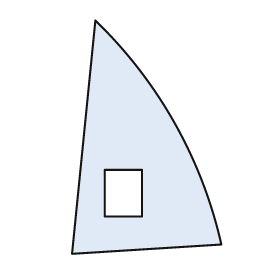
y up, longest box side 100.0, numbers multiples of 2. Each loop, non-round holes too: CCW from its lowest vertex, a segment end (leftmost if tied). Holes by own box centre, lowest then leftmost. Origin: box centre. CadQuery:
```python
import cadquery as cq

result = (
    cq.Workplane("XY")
    .moveTo(-32.0, -50.0)
    .lineTo(32.0, -46.0)
    .threePointArc((12.0, 6.0), (-22.0, 50.0))
    .close()
    .moveTo(-18.0, -34.0)
    .lineTo(-2.0, -34.0)
    .lineTo(-2.0, -14.0)
    .lineTo(-18.0, -14.0)
    .close()
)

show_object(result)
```